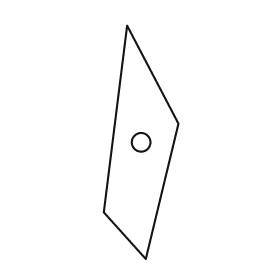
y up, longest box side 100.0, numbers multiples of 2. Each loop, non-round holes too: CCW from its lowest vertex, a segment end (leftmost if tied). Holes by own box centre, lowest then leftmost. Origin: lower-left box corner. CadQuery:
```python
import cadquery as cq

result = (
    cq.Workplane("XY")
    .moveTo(18.0, 0.0)
    .lineTo(32.0, 58.0)
    .lineTo(10.0, 100.0)
    .lineTo(0.0, 20.0)
    .close()
    .moveTo(16.0, 50.0)
    .circle(4.0)
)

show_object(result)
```